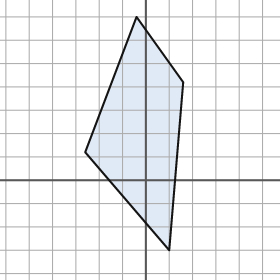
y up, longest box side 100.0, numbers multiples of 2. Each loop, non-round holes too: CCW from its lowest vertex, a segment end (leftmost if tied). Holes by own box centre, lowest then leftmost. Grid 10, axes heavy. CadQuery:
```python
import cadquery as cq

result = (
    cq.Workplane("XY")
    .moveTo(10.0, -30.0)
    .lineTo(16.0, 42.0)
    .lineTo(-4.0, 70.0)
    .lineTo(-26.0, 12.0)
    .close()
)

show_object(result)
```